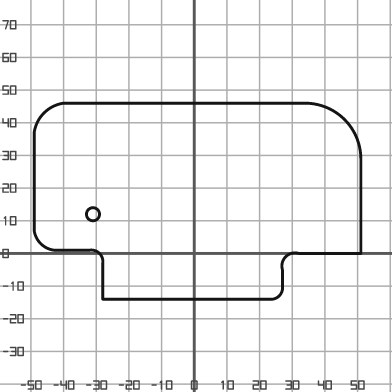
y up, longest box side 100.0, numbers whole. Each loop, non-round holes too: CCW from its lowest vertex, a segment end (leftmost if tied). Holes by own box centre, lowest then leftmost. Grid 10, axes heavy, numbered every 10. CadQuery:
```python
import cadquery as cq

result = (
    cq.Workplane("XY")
    .moveTo(-28.0, -14.0)
    .lineTo(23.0, -14.0)
    .threePointArc((26.0, -13.0), (27.0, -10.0))
    .lineTo(27.0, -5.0)
    .threePointArc((28.0, -1.0), (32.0, 0.0))
    .lineTo(51.0, 0.0)
    .lineTo(51.0, 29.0)
    .threePointArc((46.0, 41.0), (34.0, 46.0))
    .lineTo(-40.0, 46.0)
    .threePointArc((-46.0, 43.0), (-49.0, 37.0))
    .lineTo(-49.0, 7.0)
    .threePointArc((-47.0, 3.0), (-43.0, 1.0))
    .lineTo(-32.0, 1.0)
    .threePointArc((-29.0, 0.0), (-28.0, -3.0))
    .close()
    .moveTo(-31.0, 12.0)
    .circle(2.0)
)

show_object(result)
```